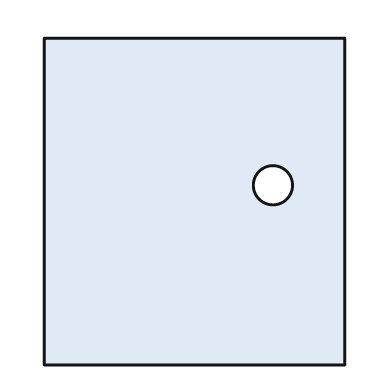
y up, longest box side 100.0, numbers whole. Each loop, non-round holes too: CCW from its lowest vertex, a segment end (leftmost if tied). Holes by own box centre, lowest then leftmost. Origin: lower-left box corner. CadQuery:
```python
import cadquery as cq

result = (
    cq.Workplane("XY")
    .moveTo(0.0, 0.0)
    .lineTo(92.0, 0.0)
    .lineTo(92.0, 100.0)
    .lineTo(0.0, 100.0)
    .close()
    .moveTo(70.0, 55.0)
    .circle(6.0)
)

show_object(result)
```